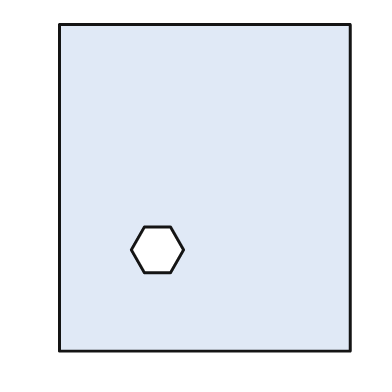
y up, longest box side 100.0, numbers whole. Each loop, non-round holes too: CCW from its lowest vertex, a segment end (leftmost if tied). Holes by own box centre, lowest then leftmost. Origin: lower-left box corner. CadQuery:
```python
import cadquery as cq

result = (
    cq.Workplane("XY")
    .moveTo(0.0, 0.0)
    .lineTo(89.0, 0.0)
    .lineTo(89.0, 100.0)
    .lineTo(0.0, 100.0)
    .close()
    .moveTo(26.0, 24.0)
    .lineTo(34.0, 24.0)
    .lineTo(38.0, 31.0)
    .lineTo(34.0, 38.0)
    .lineTo(26.0, 38.0)
    .lineTo(22.0, 31.0)
    .close()
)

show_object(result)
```